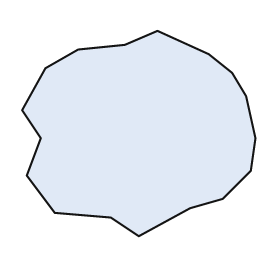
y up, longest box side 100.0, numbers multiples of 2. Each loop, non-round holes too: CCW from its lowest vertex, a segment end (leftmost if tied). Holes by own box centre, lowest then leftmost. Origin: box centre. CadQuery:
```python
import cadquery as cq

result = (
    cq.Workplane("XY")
    .moveTo(0.0, -44.0)
    .lineTo(22.0, -32.0)
    .lineTo(36.0, -28.0)
    .lineTo(48.0, -16.0)
    .lineTo(50.0, -2.0)
    .lineTo(46.0, 16.0)
    .lineTo(40.0, 26.0)
    .lineTo(30.0, 34.0)
    .lineTo(8.0, 44.0)
    .lineTo(-6.0, 38.0)
    .lineTo(-26.0, 36.0)
    .lineTo(-40.0, 28.0)
    .lineTo(-50.0, 10.0)
    .lineTo(-42.0, -2.0)
    .lineTo(-48.0, -18.0)
    .lineTo(-36.0, -34.0)
    .lineTo(-12.0, -36.0)
    .close()
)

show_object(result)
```